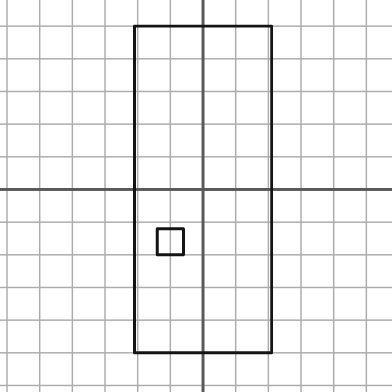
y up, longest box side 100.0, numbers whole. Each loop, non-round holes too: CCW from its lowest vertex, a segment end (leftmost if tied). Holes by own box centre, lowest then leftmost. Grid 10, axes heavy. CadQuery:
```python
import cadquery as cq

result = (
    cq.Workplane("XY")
    .moveTo(-21.0, -50.0)
    .lineTo(21.0, -50.0)
    .lineTo(21.0, 50.0)
    .lineTo(-21.0, 50.0)
    .close()
    .moveTo(-14.0, -20.0)
    .lineTo(-6.0, -20.0)
    .lineTo(-6.0, -12.0)
    .lineTo(-14.0, -12.0)
    .close()
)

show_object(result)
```